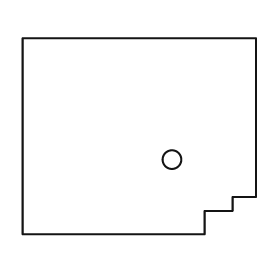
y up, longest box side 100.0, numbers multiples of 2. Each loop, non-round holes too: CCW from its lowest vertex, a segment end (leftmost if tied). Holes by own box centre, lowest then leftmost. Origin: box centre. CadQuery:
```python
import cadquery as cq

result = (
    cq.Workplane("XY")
    .moveTo(-50.0, -42.0)
    .lineTo(28.0, -42.0)
    .lineTo(28.0, -32.0)
    .lineTo(40.0, -32.0)
    .lineTo(40.0, -26.0)
    .lineTo(50.0, -26.0)
    .lineTo(50.0, 42.0)
    .lineTo(-50.0, 42.0)
    .close()
    .moveTo(14.0, -10.0)
    .circle(4.0)
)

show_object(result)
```